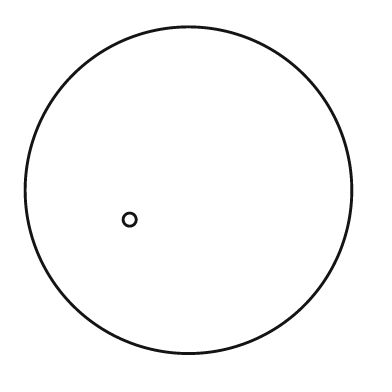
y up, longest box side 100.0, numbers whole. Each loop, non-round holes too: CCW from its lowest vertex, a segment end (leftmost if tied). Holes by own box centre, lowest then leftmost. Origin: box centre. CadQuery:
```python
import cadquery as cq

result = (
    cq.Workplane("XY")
    .moveTo(0.0, 0.0)
    .circle(50.0)
    .moveTo(-18.0, -9.0)
    .circle(2.0)
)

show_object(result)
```